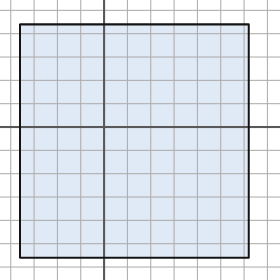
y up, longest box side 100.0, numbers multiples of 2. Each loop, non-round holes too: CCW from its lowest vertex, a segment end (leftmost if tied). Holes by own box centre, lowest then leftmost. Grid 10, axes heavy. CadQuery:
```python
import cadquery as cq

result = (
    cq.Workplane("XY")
    .moveTo(-36.0, -56.0)
    .lineTo(62.0, -56.0)
    .lineTo(62.0, 44.0)
    .lineTo(-36.0, 44.0)
    .close()
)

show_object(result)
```